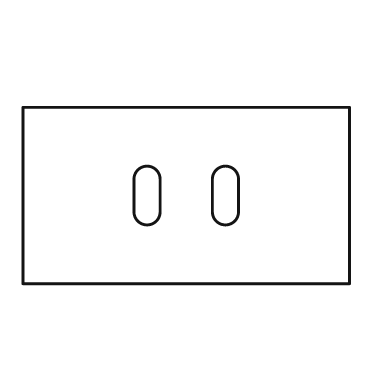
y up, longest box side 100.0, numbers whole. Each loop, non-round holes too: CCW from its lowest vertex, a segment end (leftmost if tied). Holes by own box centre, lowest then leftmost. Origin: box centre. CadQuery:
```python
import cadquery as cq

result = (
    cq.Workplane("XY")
    .moveTo(-50.0, -27.0)
    .lineTo(50.0, -27.0)
    .lineTo(50.0, 27.0)
    .lineTo(-50.0, 27.0)
    .close()
    .moveTo(-16.0, -5.0)
    .threePointArc((-12.0, -9.0), (-8.0, -5.0))
    .lineTo(-8.0, 5.0)
    .threePointArc((-12.0, 9.0), (-16.0, 5.0))
    .close()
    .moveTo(8.0, -5.0)
    .threePointArc((12.0, -9.0), (16.0, -5.0))
    .lineTo(16.0, 5.0)
    .threePointArc((12.0, 9.0), (8.0, 5.0))
    .close()
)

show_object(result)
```